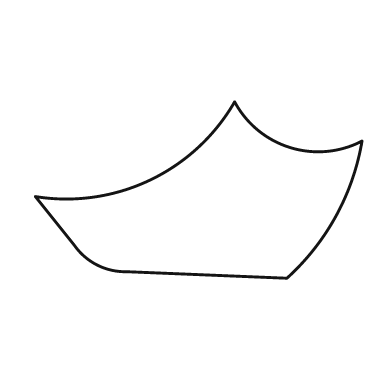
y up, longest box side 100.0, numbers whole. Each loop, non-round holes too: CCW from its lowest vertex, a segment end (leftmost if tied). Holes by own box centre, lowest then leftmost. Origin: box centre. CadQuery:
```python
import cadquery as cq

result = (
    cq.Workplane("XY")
    .moveTo(27.0, -27.0)
    .threePointArc((42.0, -8.0), (50.0, 15.0))
    .threePointArc((28.0, 13.0), (11.0, 27.0))
    .threePointArc((-15.0, 3.0), (-50.0, -2.0))
    .lineTo(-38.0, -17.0)
    .threePointArc((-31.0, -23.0), (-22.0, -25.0))
    .close()
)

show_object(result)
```